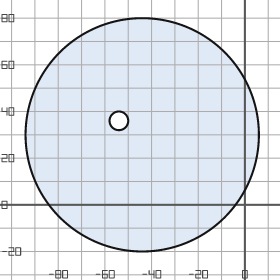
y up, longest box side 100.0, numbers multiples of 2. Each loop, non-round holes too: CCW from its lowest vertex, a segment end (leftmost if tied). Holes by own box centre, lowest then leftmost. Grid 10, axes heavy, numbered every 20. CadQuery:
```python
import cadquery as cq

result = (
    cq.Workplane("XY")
    .moveTo(-44.0, 30.0)
    .circle(50.0)
    .moveTo(-54.0, 36.0)
    .circle(4.0)
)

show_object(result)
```